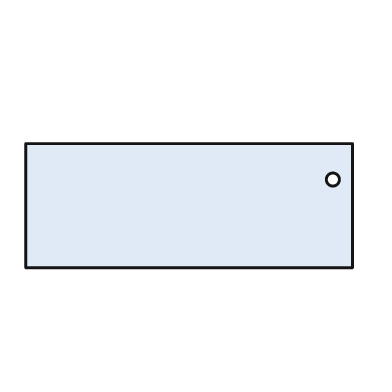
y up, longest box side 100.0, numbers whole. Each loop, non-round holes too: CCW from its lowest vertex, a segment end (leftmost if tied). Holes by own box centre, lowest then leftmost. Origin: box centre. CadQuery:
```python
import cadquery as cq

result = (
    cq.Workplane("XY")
    .moveTo(-50.0, -19.0)
    .lineTo(50.0, -19.0)
    .lineTo(50.0, 19.0)
    .lineTo(-50.0, 19.0)
    .close()
    .moveTo(44.0, 8.0)
    .circle(2.0)
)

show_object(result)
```